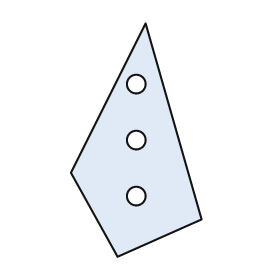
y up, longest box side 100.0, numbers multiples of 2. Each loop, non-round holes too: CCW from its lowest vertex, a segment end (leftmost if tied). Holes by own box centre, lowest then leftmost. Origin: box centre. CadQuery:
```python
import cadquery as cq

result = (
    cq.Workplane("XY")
    .moveTo(-8.0, -50.0)
    .lineTo(28.0, -34.0)
    .lineTo(4.0, 50.0)
    .lineTo(-28.0, -14.0)
    .close()
    .moveTo(0.0, -24.0)
    .circle(4.0)
    .moveTo(0.0, 0.0)
    .circle(4.0)
    .moveTo(0.0, 24.0)
    .circle(4.0)
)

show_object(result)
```